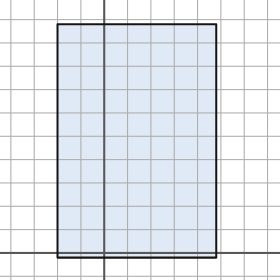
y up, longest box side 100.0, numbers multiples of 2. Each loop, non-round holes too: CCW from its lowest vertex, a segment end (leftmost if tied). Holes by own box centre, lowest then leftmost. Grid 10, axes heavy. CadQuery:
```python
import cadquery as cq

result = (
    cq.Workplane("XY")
    .moveTo(-20.0, -2.0)
    .lineTo(48.0, -2.0)
    .lineTo(48.0, 98.0)
    .lineTo(-20.0, 98.0)
    .close()
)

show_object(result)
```